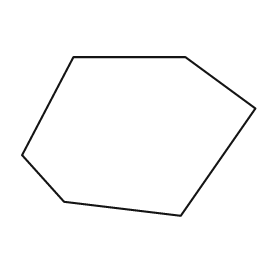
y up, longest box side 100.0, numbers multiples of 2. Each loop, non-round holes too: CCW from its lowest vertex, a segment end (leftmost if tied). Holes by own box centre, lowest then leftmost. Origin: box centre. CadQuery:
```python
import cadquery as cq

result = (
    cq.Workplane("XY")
    .moveTo(18.0, -34.0)
    .lineTo(50.0, 12.0)
    .lineTo(20.0, 34.0)
    .lineTo(-28.0, 34.0)
    .lineTo(-50.0, -8.0)
    .lineTo(-32.0, -28.0)
    .close()
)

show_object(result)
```